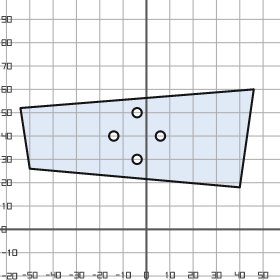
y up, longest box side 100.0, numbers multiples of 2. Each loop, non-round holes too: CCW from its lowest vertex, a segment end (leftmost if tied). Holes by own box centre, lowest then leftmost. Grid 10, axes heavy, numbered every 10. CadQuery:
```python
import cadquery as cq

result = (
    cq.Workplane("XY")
    .moveTo(40.0, 18.0)
    .lineTo(46.0, 60.0)
    .lineTo(-54.0, 52.0)
    .lineTo(-50.0, 26.0)
    .close()
    .moveTo(-4.0, 30.0)
    .circle(2.0)
    .moveTo(-14.0, 40.0)
    .circle(2.0)
    .moveTo(6.0, 40.0)
    .circle(2.0)
    .moveTo(-4.0, 50.0)
    .circle(2.0)
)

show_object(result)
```